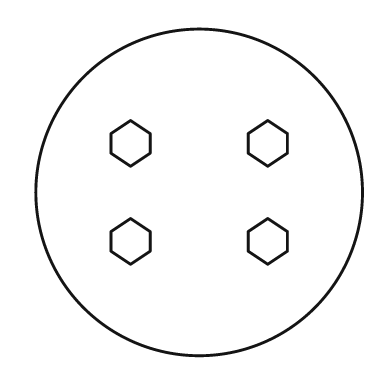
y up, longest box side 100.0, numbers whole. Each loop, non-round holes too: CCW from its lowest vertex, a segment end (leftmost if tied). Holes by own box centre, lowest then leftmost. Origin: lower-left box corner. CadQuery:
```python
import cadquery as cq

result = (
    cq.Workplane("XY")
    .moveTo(50.0, 50.0)
    .circle(50.0)
    .moveTo(29.0, 28.0)
    .lineTo(35.0, 32.0)
    .lineTo(35.0, 38.0)
    .lineTo(29.0, 42.0)
    .lineTo(23.0, 38.0)
    .lineTo(23.0, 32.0)
    .close()
    .moveTo(71.0, 28.0)
    .lineTo(77.0, 32.0)
    .lineTo(77.0, 38.0)
    .lineTo(71.0, 42.0)
    .lineTo(65.0, 38.0)
    .lineTo(65.0, 32.0)
    .close()
    .moveTo(29.0, 58.0)
    .lineTo(35.0, 62.0)
    .lineTo(35.0, 68.0)
    .lineTo(29.0, 72.0)
    .lineTo(23.0, 68.0)
    .lineTo(23.0, 62.0)
    .close()
    .moveTo(71.0, 58.0)
    .lineTo(77.0, 62.0)
    .lineTo(77.0, 68.0)
    .lineTo(71.0, 72.0)
    .lineTo(65.0, 68.0)
    .lineTo(65.0, 62.0)
    .close()
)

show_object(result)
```